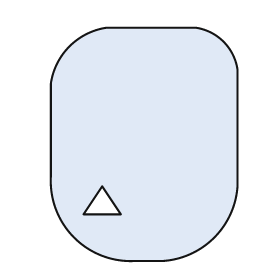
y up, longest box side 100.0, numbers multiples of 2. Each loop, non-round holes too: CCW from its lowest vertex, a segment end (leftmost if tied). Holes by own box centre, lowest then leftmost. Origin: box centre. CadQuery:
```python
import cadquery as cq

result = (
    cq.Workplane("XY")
    .moveTo(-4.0, -50.0)
    .lineTo(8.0, -50.0)
    .threePointArc((30.0, -40.0), (40.0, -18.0))
    .lineTo(40.0, 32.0)
    .threePointArc((34.0, 44.0), (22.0, 50.0))
    .lineTo(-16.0, 50.0)
    .threePointArc((-32.0, 42.0), (-40.0, 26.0))
    .lineTo(-40.0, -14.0)
    .threePointArc((-30.0, -40.0), (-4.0, -50.0))
    .close()
    .moveTo(-26.0, -30.0)
    .lineTo(-10.0, -30.0)
    .lineTo(-18.0, -18.0)
    .close()
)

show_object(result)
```